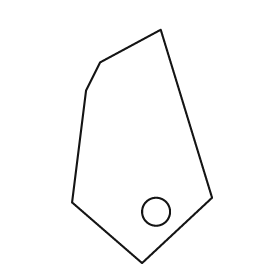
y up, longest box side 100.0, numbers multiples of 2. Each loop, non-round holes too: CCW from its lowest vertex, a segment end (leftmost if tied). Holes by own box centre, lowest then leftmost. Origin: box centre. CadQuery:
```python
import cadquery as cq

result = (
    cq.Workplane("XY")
    .moveTo(0.0, -50.0)
    .lineTo(30.0, -22.0)
    .lineTo(8.0, 50.0)
    .lineTo(-18.0, 36.0)
    .lineTo(-24.0, 24.0)
    .lineTo(-30.0, -24.0)
    .close()
    .moveTo(6.0, -28.0)
    .circle(6.0)
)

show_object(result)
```